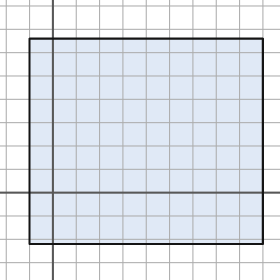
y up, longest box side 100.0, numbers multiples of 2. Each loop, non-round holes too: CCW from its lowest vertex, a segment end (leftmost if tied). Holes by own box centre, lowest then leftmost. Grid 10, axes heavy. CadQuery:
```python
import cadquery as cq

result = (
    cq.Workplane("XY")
    .moveTo(-10.0, -22.0)
    .lineTo(90.0, -22.0)
    .lineTo(90.0, 66.0)
    .lineTo(-10.0, 66.0)
    .close()
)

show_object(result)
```